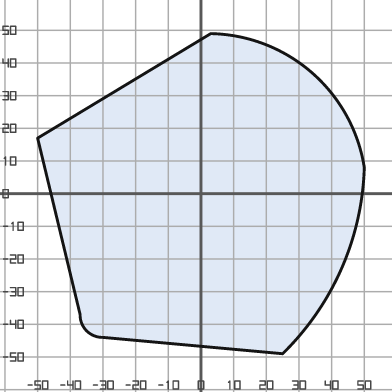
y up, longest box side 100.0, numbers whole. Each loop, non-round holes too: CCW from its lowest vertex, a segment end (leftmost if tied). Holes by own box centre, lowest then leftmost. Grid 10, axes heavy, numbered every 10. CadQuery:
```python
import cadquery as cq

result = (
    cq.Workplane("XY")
    .moveTo(25.0, -49.0)
    .threePointArc((43.0, -23.0), (50.0, 8.0))
    .threePointArc((34.0, 37.0), (3.0, 49.0))
    .lineTo(-50.0, 17.0)
    .lineTo(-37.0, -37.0)
    .threePointArc((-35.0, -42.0), (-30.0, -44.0))
    .close()
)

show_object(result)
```